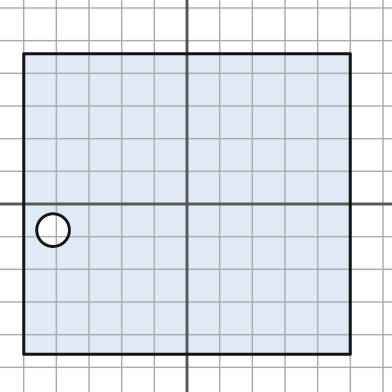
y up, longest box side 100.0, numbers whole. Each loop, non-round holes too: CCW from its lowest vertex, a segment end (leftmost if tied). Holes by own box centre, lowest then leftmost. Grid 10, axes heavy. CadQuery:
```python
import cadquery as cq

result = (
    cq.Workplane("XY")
    .moveTo(-50.0, -46.0)
    .lineTo(50.0, -46.0)
    .lineTo(50.0, 46.0)
    .lineTo(-50.0, 46.0)
    .close()
    .moveTo(-41.0, -8.0)
    .circle(5.0)
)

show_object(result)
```